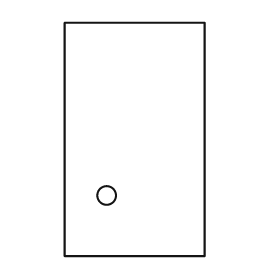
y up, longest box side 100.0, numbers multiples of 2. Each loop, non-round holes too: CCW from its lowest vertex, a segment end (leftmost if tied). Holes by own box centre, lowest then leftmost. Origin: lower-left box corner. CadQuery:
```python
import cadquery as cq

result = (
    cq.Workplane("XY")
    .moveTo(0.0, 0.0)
    .lineTo(60.0, 0.0)
    .lineTo(60.0, 100.0)
    .lineTo(0.0, 100.0)
    .close()
    .moveTo(18.0, 26.0)
    .circle(4.0)
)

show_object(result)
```